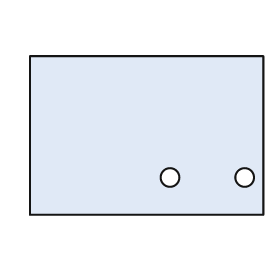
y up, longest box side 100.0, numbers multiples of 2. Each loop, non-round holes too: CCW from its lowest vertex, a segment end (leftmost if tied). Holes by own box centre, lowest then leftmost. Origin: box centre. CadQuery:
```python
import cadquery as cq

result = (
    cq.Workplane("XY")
    .moveTo(-50.0, -34.0)
    .lineTo(50.0, -34.0)
    .lineTo(50.0, 34.0)
    .lineTo(-50.0, 34.0)
    .close()
    .moveTo(10.0, -18.0)
    .circle(4.0)
    .moveTo(42.0, -18.0)
    .circle(4.0)
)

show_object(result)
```